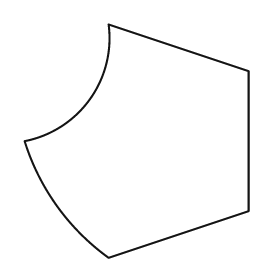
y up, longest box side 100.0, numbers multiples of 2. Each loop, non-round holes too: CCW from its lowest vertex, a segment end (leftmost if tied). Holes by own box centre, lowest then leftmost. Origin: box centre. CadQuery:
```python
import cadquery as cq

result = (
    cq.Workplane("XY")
    .moveTo(-12.0, -50.0)
    .lineTo(48.0, -30.0)
    .lineTo(48.0, 30.0)
    .lineTo(-12.0, 50.0)
    .threePointArc((-20.0, 18.0), (-48.0, 0.0))
    .threePointArc((-34.0, -28.0), (-12.0, -50.0))
    .close()
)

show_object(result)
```